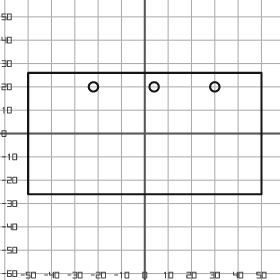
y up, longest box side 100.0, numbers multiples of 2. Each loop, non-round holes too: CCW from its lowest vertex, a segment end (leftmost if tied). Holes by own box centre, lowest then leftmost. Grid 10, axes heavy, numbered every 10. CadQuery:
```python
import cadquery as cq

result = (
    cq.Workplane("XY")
    .moveTo(-50.0, -26.0)
    .lineTo(50.0, -26.0)
    .lineTo(50.0, 26.0)
    .lineTo(-50.0, 26.0)
    .close()
    .moveTo(-22.0, 20.0)
    .circle(2.0)
    .moveTo(4.0, 20.0)
    .circle(2.0)
    .moveTo(30.0, 20.0)
    .circle(2.0)
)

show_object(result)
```